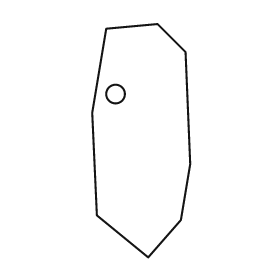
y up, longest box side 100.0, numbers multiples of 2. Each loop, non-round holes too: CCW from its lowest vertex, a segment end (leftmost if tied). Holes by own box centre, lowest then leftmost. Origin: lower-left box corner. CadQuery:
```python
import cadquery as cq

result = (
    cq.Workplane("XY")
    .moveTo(24.0, 0.0)
    .lineTo(38.0, 16.0)
    .lineTo(42.0, 40.0)
    .lineTo(40.0, 88.0)
    .lineTo(28.0, 100.0)
    .lineTo(6.0, 98.0)
    .lineTo(0.0, 62.0)
    .lineTo(2.0, 18.0)
    .close()
    .moveTo(10.0, 70.0)
    .circle(4.0)
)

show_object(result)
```